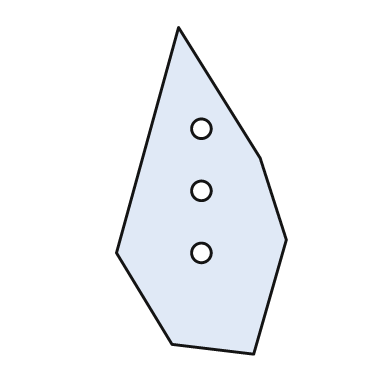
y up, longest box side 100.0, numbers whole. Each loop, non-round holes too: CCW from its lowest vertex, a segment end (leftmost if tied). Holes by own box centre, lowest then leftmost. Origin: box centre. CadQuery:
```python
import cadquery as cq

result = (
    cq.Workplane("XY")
    .moveTo(16.0, -50.0)
    .lineTo(26.0, -15.0)
    .lineTo(18.0, 10.0)
    .lineTo(-7.0, 50.0)
    .lineTo(-26.0, -19.0)
    .lineTo(-9.0, -47.0)
    .close()
    .moveTo(0.0, -19.0)
    .circle(3.0)
    .moveTo(0.0, 0.0)
    .circle(3.0)
    .moveTo(0.0, 19.0)
    .circle(3.0)
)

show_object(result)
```